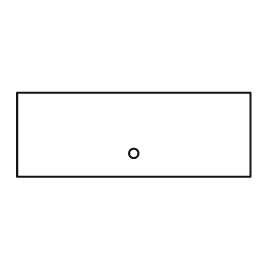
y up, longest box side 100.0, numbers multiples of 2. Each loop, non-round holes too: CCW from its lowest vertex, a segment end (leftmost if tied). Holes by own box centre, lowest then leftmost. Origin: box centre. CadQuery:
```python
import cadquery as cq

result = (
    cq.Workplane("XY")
    .moveTo(-50.0, -18.0)
    .lineTo(50.0, -18.0)
    .lineTo(50.0, 18.0)
    .lineTo(-50.0, 18.0)
    .close()
    .moveTo(0.0, -8.0)
    .circle(2.0)
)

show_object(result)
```